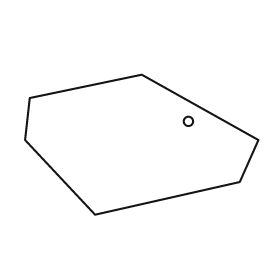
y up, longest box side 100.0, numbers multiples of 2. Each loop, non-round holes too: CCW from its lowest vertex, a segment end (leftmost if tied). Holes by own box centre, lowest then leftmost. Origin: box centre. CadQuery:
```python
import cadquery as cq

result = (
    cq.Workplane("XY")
    .moveTo(-20.0, -30.0)
    .lineTo(42.0, -16.0)
    .lineTo(50.0, 2.0)
    .lineTo(0.0, 30.0)
    .lineTo(-48.0, 20.0)
    .lineTo(-50.0, 2.0)
    .close()
    .moveTo(20.0, 10.0)
    .circle(2.0)
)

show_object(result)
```